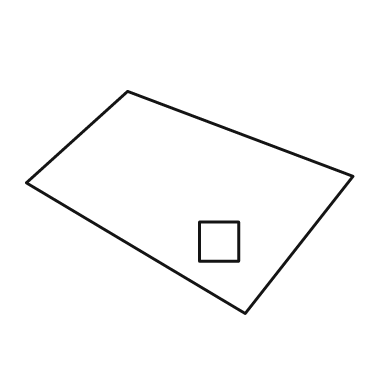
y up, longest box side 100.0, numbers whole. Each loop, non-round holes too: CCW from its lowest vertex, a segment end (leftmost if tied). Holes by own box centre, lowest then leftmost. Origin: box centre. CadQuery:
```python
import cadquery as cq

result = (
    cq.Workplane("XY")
    .moveTo(17.0, -34.0)
    .lineTo(50.0, 8.0)
    .lineTo(-19.0, 34.0)
    .lineTo(-50.0, 6.0)
    .close()
    .moveTo(3.0, -18.0)
    .lineTo(15.0, -18.0)
    .lineTo(15.0, -6.0)
    .lineTo(3.0, -6.0)
    .close()
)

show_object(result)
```